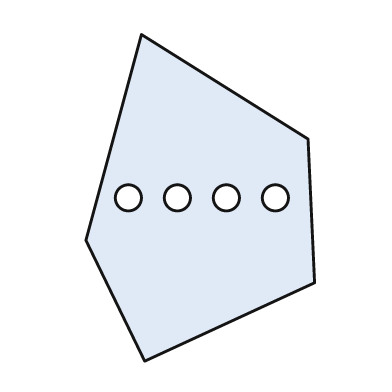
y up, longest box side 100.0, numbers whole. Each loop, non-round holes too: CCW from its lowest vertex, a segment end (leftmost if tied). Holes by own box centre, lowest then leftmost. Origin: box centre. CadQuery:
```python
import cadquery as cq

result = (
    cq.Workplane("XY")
    .moveTo(-17.0, -50.0)
    .lineTo(35.0, -26.0)
    .lineTo(33.0, 18.0)
    .lineTo(-18.0, 50.0)
    .lineTo(-35.0, -13.0)
    .close()
    .moveTo(-22.0, 0.0)
    .circle(4.0)
    .moveTo(-7.0, 0.0)
    .circle(4.0)
    .moveTo(8.0, 0.0)
    .circle(4.0)
    .moveTo(23.0, 0.0)
    .circle(4.0)
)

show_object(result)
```